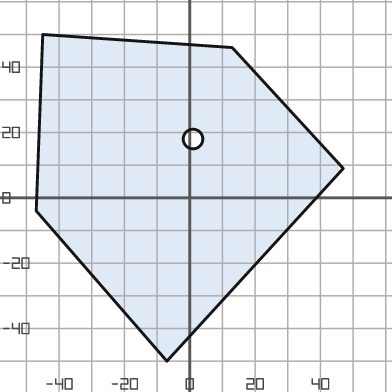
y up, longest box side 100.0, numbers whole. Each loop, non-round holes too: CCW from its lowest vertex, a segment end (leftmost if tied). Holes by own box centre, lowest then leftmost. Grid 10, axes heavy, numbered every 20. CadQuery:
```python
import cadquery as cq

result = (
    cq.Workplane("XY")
    .moveTo(-7.0, -50.0)
    .lineTo(47.0, 9.0)
    .lineTo(13.0, 46.0)
    .lineTo(-45.0, 50.0)
    .lineTo(-47.0, -4.0)
    .close()
    .moveTo(1.0, 18.0)
    .circle(3.0)
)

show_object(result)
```